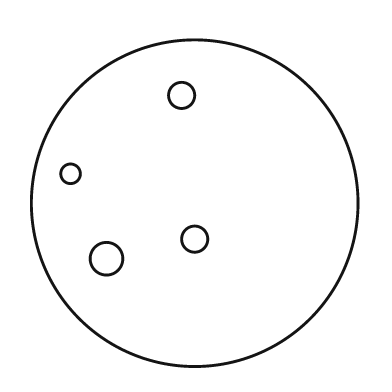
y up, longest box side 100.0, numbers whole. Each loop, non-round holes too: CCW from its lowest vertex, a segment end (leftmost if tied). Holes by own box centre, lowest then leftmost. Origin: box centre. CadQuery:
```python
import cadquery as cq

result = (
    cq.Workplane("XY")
    .moveTo(0.0, 0.0)
    .circle(50.0)
    .moveTo(-27.0, -17.0)
    .circle(5.0)
    .moveTo(0.0, -11.0)
    .circle(4.0)
    .moveTo(-38.0, 9.0)
    .circle(3.0)
    .moveTo(-4.0, 33.0)
    .circle(4.0)
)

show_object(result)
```